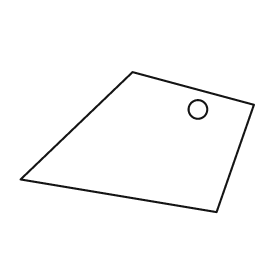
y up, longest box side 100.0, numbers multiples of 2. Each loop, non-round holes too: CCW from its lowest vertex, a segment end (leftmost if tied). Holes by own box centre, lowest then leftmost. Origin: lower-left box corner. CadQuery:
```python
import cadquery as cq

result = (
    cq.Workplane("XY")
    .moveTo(84.0, 0.0)
    .lineTo(100.0, 46.0)
    .lineTo(48.0, 60.0)
    .lineTo(0.0, 14.0)
    .close()
    .moveTo(76.0, 44.0)
    .circle(4.0)
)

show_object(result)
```